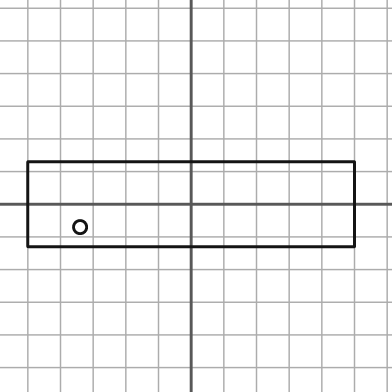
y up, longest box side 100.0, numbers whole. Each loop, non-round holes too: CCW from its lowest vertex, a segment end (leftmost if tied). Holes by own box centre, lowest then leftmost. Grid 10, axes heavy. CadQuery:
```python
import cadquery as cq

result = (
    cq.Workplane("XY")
    .moveTo(-50.0, -13.0)
    .lineTo(50.0, -13.0)
    .lineTo(50.0, 13.0)
    .lineTo(-50.0, 13.0)
    .close()
    .moveTo(-34.0, -7.0)
    .circle(2.0)
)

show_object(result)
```